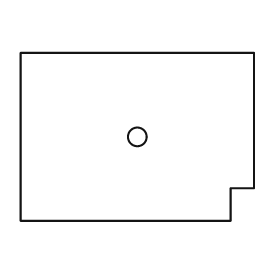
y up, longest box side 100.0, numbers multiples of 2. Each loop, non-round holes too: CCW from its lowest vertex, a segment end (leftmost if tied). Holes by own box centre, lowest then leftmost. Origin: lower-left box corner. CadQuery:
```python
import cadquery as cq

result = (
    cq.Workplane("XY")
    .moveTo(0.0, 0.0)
    .lineTo(90.0, 0.0)
    .lineTo(90.0, 14.0)
    .lineTo(100.0, 14.0)
    .lineTo(100.0, 72.0)
    .lineTo(0.0, 72.0)
    .close()
    .moveTo(50.0, 36.0)
    .circle(4.0)
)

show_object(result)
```